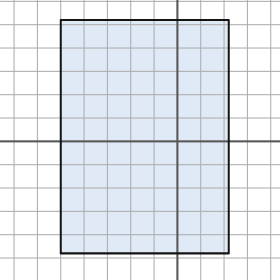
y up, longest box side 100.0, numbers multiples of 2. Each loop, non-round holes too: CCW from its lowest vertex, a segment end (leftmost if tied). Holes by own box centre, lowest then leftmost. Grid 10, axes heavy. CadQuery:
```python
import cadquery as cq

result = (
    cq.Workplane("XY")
    .moveTo(-50.0, -48.0)
    .lineTo(22.0, -48.0)
    .lineTo(22.0, 52.0)
    .lineTo(-50.0, 52.0)
    .close()
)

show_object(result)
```